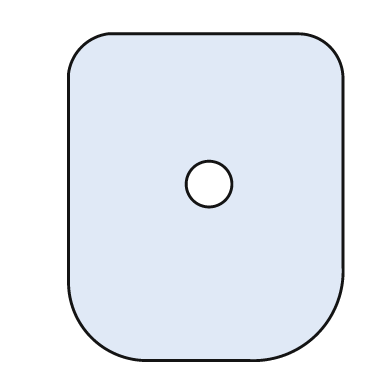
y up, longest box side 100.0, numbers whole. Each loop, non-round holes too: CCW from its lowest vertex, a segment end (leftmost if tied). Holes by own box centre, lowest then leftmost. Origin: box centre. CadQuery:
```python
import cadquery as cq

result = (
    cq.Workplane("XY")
    .moveTo(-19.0, -50.0)
    .lineTo(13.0, -50.0)
    .threePointArc((34.0, -42.0), (42.0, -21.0))
    .lineTo(42.0, 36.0)
    .threePointArc((38.0, 46.0), (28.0, 50.0))
    .lineTo(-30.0, 50.0)
    .threePointArc((-38.0, 46.0), (-42.0, 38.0))
    .lineTo(-42.0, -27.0)
    .threePointArc((-35.0, -43.0), (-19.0, -50.0))
    .close()
    .moveTo(1.0, 4.0)
    .circle(7.0)
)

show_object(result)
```